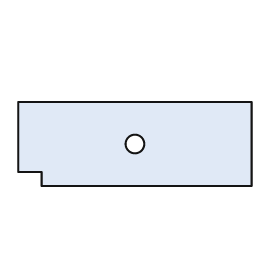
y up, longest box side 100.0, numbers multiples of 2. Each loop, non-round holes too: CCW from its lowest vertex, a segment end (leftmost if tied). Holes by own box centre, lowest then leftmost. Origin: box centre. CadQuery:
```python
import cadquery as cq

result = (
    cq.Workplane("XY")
    .moveTo(-40.0, -18.0)
    .lineTo(50.0, -18.0)
    .lineTo(50.0, 18.0)
    .lineTo(-50.0, 18.0)
    .lineTo(-50.0, -12.0)
    .lineTo(-40.0, -12.0)
    .close()
    .moveTo(0.0, 0.0)
    .circle(4.0)
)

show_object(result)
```